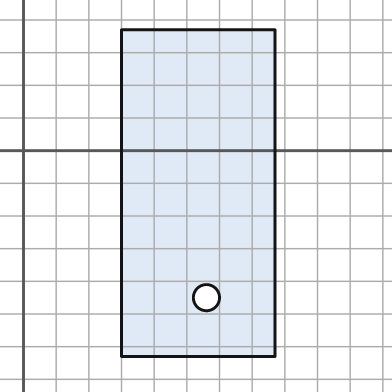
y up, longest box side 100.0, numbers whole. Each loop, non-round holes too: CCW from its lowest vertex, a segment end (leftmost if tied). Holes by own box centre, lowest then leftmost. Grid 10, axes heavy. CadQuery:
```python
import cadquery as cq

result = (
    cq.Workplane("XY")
    .moveTo(30.0, -63.0)
    .lineTo(77.0, -63.0)
    .lineTo(77.0, 37.0)
    .lineTo(30.0, 37.0)
    .close()
    .moveTo(56.0, -45.0)
    .circle(4.0)
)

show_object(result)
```